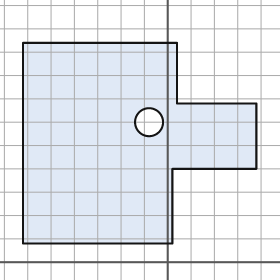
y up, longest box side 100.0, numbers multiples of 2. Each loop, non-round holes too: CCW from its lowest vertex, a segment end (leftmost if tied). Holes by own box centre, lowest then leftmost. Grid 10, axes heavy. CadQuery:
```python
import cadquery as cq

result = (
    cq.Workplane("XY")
    .moveTo(-62.0, 8.0)
    .lineTo(2.0, 8.0)
    .lineTo(2.0, 40.0)
    .lineTo(38.0, 40.0)
    .lineTo(38.0, 68.0)
    .lineTo(4.0, 68.0)
    .lineTo(4.0, 94.0)
    .lineTo(-62.0, 94.0)
    .close()
    .moveTo(-8.0, 60.0)
    .circle(6.0)
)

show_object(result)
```